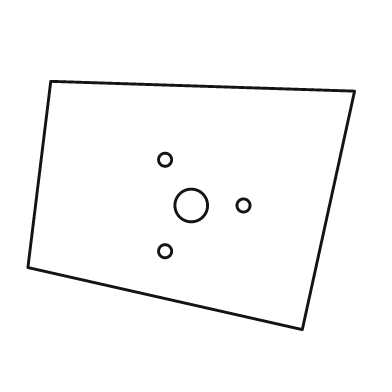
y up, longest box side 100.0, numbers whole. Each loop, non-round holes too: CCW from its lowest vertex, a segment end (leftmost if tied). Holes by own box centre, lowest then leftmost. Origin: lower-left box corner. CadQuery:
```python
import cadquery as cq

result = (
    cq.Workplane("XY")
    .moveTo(84.0, 0.0)
    .lineTo(100.0, 73.0)
    .lineTo(7.0, 76.0)
    .lineTo(0.0, 19.0)
    .close()
    .moveTo(42.0, 24.0)
    .circle(2.0)
    .moveTo(50.0, 38.0)
    .circle(5.0)
    .moveTo(66.0, 38.0)
    .circle(2.0)
    .moveTo(42.0, 52.0)
    .circle(2.0)
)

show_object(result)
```